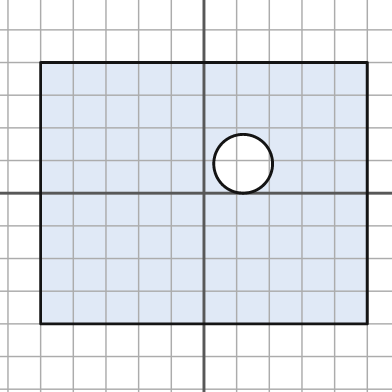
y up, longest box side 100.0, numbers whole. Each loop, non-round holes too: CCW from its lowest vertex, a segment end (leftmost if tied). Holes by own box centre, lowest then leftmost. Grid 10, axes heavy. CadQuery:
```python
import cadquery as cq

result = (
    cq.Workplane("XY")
    .moveTo(-50.0, -40.0)
    .lineTo(50.0, -40.0)
    .lineTo(50.0, 40.0)
    .lineTo(-50.0, 40.0)
    .close()
    .moveTo(12.0, 9.0)
    .circle(9.0)
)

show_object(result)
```